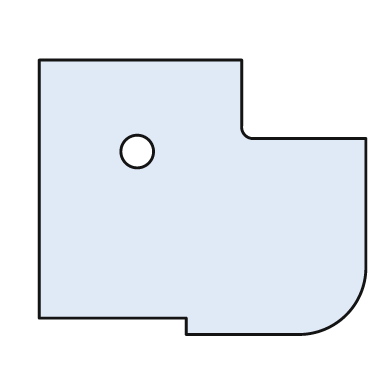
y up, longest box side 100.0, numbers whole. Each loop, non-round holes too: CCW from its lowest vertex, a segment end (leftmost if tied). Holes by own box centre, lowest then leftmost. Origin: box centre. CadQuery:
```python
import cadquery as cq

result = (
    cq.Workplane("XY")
    .moveTo(-5.0, -42.0)
    .lineTo(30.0, -42.0)
    .threePointArc((44.0, -36.0), (50.0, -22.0))
    .lineTo(50.0, 18.0)
    .lineTo(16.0, 18.0)
    .threePointArc((13.0, 19.0), (12.0, 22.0))
    .lineTo(12.0, 42.0)
    .lineTo(-50.0, 42.0)
    .lineTo(-50.0, -37.0)
    .lineTo(-5.0, -37.0)
    .close()
    .moveTo(-20.0, 14.0)
    .circle(5.0)
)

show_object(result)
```